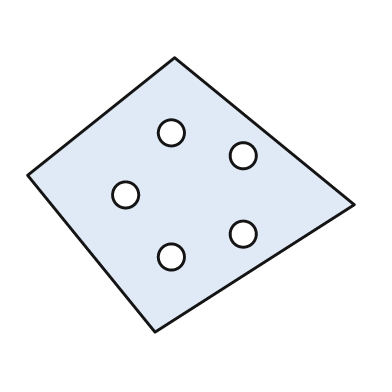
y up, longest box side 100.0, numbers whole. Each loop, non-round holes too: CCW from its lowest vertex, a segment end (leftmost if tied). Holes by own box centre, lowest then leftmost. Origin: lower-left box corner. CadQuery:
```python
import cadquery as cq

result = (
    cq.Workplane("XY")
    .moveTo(39.0, 0.0)
    .lineTo(100.0, 39.0)
    .lineTo(45.0, 84.0)
    .lineTo(0.0, 48.0)
    .close()
    .moveTo(44.0, 23.0)
    .circle(4.0)
    .moveTo(66.0, 30.0)
    .circle(4.0)
    .moveTo(30.0, 42.0)
    .circle(4.0)
    .moveTo(66.0, 54.0)
    .circle(4.0)
    .moveTo(44.0, 61.0)
    .circle(4.0)
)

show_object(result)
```